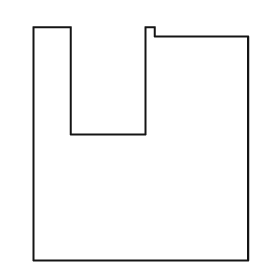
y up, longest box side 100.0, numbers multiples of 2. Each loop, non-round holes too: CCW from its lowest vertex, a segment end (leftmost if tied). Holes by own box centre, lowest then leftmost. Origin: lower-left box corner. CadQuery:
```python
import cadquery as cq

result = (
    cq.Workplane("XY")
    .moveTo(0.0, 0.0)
    .lineTo(92.0, 0.0)
    .lineTo(92.0, 96.0)
    .lineTo(52.0, 96.0)
    .lineTo(52.0, 100.0)
    .lineTo(48.0, 100.0)
    .lineTo(48.0, 54.0)
    .lineTo(16.0, 54.0)
    .lineTo(16.0, 100.0)
    .lineTo(0.0, 100.0)
    .close()
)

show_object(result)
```